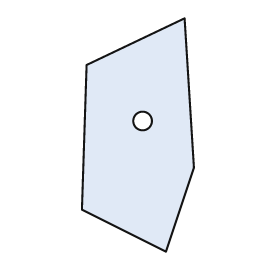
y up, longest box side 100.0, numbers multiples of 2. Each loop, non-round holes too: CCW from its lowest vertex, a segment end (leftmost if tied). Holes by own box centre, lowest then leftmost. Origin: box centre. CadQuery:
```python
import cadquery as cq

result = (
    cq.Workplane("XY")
    .moveTo(12.0, -50.0)
    .lineTo(24.0, -14.0)
    .lineTo(20.0, 50.0)
    .lineTo(-22.0, 30.0)
    .lineTo(-24.0, -32.0)
    .close()
    .moveTo(2.0, 6.0)
    .circle(4.0)
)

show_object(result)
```